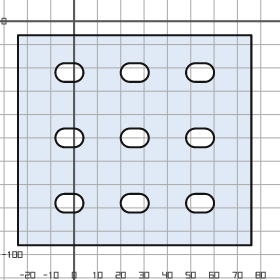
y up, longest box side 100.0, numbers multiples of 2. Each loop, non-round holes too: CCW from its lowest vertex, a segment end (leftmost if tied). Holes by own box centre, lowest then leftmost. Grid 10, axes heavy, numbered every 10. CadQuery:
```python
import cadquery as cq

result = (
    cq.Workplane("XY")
    .moveTo(-24.0, -96.0)
    .lineTo(76.0, -96.0)
    .lineTo(76.0, -6.0)
    .lineTo(-24.0, -6.0)
    .close()
    .moveTo(-4.0, -82.0)
    .lineTo(0.0, -82.0)
    .threePointArc((4.0, -78.0), (0.0, -74.0))
    .lineTo(-4.0, -74.0)
    .threePointArc((-8.0, -78.0), (-4.0, -82.0))
    .close()
    .moveTo(24.0, -82.0)
    .lineTo(28.0, -82.0)
    .threePointArc((32.0, -78.0), (28.0, -74.0))
    .lineTo(24.0, -74.0)
    .threePointArc((20.0, -78.0), (24.0, -82.0))
    .close()
    .moveTo(52.0, -82.0)
    .lineTo(56.0, -82.0)
    .threePointArc((60.0, -78.0), (56.0, -74.0))
    .lineTo(52.0, -74.0)
    .threePointArc((48.0, -78.0), (52.0, -82.0))
    .close()
    .moveTo(-4.0, -54.0)
    .lineTo(0.0, -54.0)
    .threePointArc((4.0, -50.0), (0.0, -46.0))
    .lineTo(-4.0, -46.0)
    .threePointArc((-8.0, -50.0), (-4.0, -54.0))
    .close()
    .moveTo(24.0, -54.0)
    .lineTo(28.0, -54.0)
    .threePointArc((32.0, -50.0), (28.0, -46.0))
    .lineTo(24.0, -46.0)
    .threePointArc((20.0, -50.0), (24.0, -54.0))
    .close()
    .moveTo(52.0, -54.0)
    .lineTo(56.0, -54.0)
    .threePointArc((60.0, -50.0), (56.0, -46.0))
    .lineTo(52.0, -46.0)
    .threePointArc((48.0, -50.0), (52.0, -54.0))
    .close()
    .moveTo(-4.0, -26.0)
    .lineTo(0.0, -26.0)
    .threePointArc((4.0, -22.0), (0.0, -18.0))
    .lineTo(-4.0, -18.0)
    .threePointArc((-8.0, -22.0), (-4.0, -26.0))
    .close()
    .moveTo(24.0, -26.0)
    .lineTo(28.0, -26.0)
    .threePointArc((32.0, -22.0), (28.0, -18.0))
    .lineTo(24.0, -18.0)
    .threePointArc((20.0, -22.0), (24.0, -26.0))
    .close()
    .moveTo(52.0, -26.0)
    .lineTo(56.0, -26.0)
    .threePointArc((60.0, -22.0), (56.0, -18.0))
    .lineTo(52.0, -18.0)
    .threePointArc((48.0, -22.0), (52.0, -26.0))
    .close()
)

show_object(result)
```